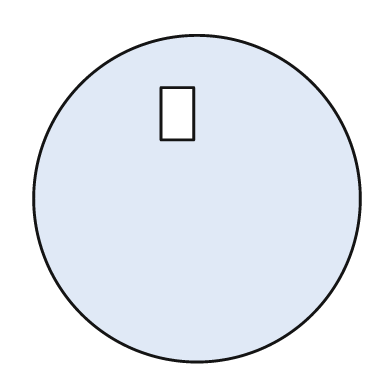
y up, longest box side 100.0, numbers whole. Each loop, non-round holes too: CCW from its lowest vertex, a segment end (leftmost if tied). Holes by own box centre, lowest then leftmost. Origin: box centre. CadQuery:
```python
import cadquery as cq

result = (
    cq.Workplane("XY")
    .moveTo(0.0, 0.0)
    .circle(50.0)
    .moveTo(-11.0, 18.0)
    .lineTo(-1.0, 18.0)
    .lineTo(-1.0, 34.0)
    .lineTo(-11.0, 34.0)
    .close()
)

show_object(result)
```